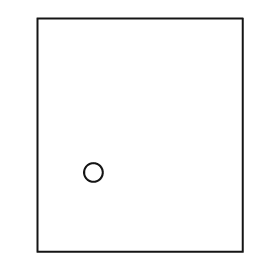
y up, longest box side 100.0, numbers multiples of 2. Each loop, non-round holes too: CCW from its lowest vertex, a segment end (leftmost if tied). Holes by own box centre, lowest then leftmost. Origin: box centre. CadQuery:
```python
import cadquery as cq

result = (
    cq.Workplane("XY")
    .moveTo(-44.0, -50.0)
    .lineTo(44.0, -50.0)
    .lineTo(44.0, 50.0)
    .lineTo(-44.0, 50.0)
    .close()
    .moveTo(-20.0, -16.0)
    .circle(4.0)
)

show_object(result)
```